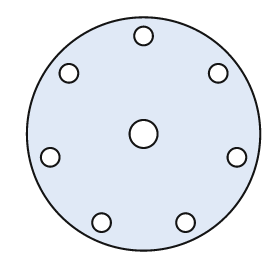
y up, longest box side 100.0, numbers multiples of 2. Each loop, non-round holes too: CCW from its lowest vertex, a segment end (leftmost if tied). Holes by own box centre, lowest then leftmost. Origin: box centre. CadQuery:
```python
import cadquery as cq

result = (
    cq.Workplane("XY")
    .moveTo(0.0, 0.0)
    .circle(50.0)
    .moveTo(-18.0, -38.0)
    .circle(4.0)
    .moveTo(18.0, -38.0)
    .circle(4.0)
    .moveTo(-40.0, -10.0)
    .circle(4.0)
    .moveTo(40.0, -10.0)
    .circle(4.0)
    .moveTo(0.0, 0.0)
    .circle(6.0)
    .moveTo(-32.0, 26.0)
    .circle(4.0)
    .moveTo(32.0, 26.0)
    .circle(4.0)
    .moveTo(0.0, 42.0)
    .circle(4.0)
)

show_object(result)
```